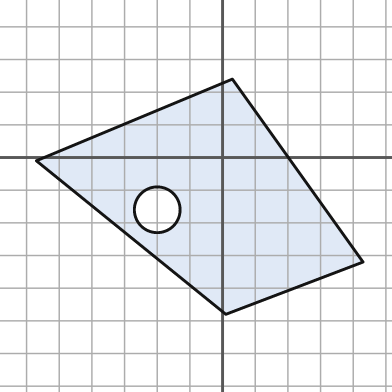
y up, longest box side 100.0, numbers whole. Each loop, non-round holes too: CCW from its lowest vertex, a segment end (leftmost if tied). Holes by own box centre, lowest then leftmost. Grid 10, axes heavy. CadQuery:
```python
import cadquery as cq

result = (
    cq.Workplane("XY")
    .moveTo(1.0, -48.0)
    .lineTo(43.0, -32.0)
    .lineTo(3.0, 24.0)
    .lineTo(-57.0, -1.0)
    .close()
    .moveTo(-20.0, -16.0)
    .circle(7.0)
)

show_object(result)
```